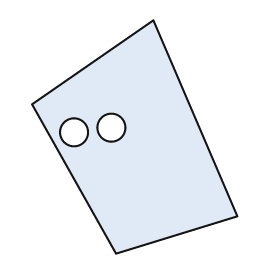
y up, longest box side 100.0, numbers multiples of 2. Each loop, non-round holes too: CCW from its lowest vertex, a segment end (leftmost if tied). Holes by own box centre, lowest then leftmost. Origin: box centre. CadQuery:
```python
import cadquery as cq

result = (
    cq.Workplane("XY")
    .moveTo(-8.0, -50.0)
    .lineTo(44.0, -34.0)
    .lineTo(8.0, 50.0)
    .lineTo(-44.0, 14.0)
    .close()
    .moveTo(-26.0, 2.0)
    .circle(6.0)
    .moveTo(-10.0, 4.0)
    .circle(6.0)
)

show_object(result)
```